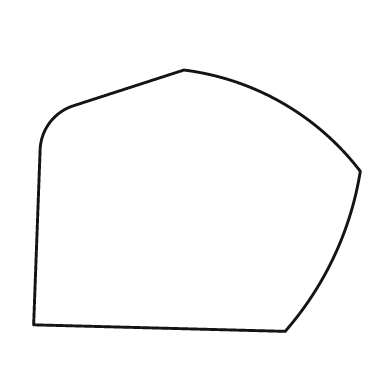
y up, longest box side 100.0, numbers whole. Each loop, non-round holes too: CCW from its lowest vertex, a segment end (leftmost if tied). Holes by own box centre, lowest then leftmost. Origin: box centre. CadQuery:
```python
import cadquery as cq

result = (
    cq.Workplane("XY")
    .moveTo(27.0, -40.0)
    .threePointArc((42.0, -17.0), (50.0, 9.0))
    .threePointArc((26.0, 30.0), (-4.0, 40.0))
    .lineTo(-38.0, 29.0)
    .threePointArc((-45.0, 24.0), (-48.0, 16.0))
    .lineTo(-50.0, -38.0)
    .close()
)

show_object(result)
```